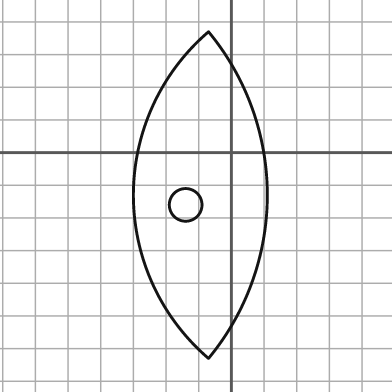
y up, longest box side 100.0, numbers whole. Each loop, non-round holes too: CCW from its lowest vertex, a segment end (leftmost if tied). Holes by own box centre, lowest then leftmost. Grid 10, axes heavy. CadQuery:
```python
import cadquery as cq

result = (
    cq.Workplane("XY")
    .moveTo(-7.0, -63.0)
    .threePointArc((11.0, -13.0), (-7.0, 37.0))
    .threePointArc((-30.0, -13.0), (-7.0, -63.0))
    .close()
    .moveTo(-14.0, -16.0)
    .circle(5.0)
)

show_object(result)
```